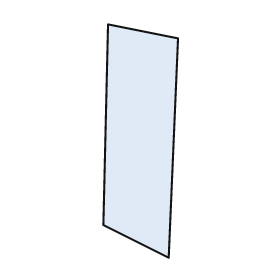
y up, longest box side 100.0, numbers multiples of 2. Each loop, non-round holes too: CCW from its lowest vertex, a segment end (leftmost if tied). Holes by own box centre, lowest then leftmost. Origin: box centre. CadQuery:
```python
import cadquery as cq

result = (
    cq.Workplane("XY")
    .moveTo(12.0, -50.0)
    .lineTo(16.0, 44.0)
    .lineTo(-14.0, 50.0)
    .lineTo(-16.0, -36.0)
    .close()
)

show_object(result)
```